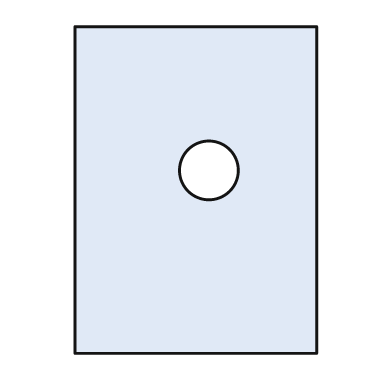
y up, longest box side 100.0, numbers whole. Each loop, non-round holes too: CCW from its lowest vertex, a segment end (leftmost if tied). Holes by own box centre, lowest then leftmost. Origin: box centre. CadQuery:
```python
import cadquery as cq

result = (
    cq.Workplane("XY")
    .moveTo(-37.0, -50.0)
    .lineTo(37.0, -50.0)
    .lineTo(37.0, 50.0)
    .lineTo(-37.0, 50.0)
    .close()
    .moveTo(4.0, 6.0)
    .circle(9.0)
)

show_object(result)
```